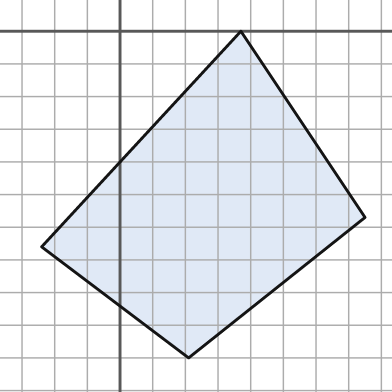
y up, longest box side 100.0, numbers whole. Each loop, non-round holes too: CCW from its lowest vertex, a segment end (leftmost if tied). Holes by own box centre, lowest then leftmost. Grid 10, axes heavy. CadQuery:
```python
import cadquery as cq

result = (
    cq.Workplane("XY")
    .moveTo(21.0, -100.0)
    .lineTo(75.0, -57.0)
    .lineTo(37.0, 0.0)
    .lineTo(-24.0, -66.0)
    .close()
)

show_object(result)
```